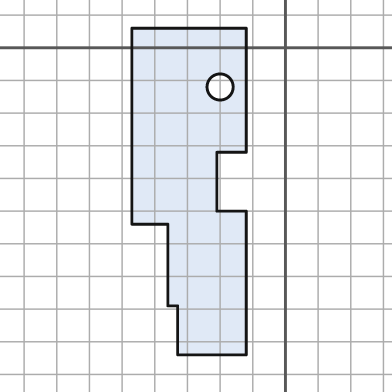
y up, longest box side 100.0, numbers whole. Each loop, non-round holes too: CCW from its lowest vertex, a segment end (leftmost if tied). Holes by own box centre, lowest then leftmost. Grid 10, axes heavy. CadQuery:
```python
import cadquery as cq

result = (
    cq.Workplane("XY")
    .moveTo(-33.0, -94.0)
    .lineTo(-12.0, -94.0)
    .lineTo(-12.0, -50.0)
    .lineTo(-21.0, -50.0)
    .lineTo(-21.0, -32.0)
    .lineTo(-12.0, -32.0)
    .lineTo(-12.0, 6.0)
    .lineTo(-47.0, 6.0)
    .lineTo(-47.0, -54.0)
    .lineTo(-36.0, -54.0)
    .lineTo(-36.0, -79.0)
    .lineTo(-33.0, -79.0)
    .close()
    .moveTo(-20.0, -12.0)
    .circle(4.0)
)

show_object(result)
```